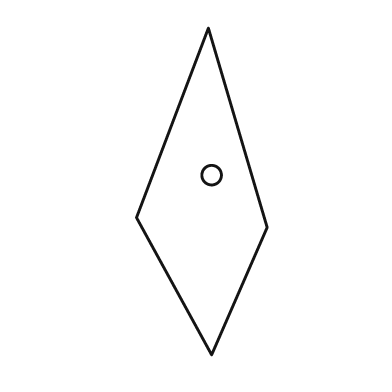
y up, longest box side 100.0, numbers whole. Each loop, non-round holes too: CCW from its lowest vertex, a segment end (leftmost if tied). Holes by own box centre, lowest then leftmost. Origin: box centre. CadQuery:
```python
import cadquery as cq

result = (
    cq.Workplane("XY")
    .moveTo(3.0, -50.0)
    .lineTo(20.0, -11.0)
    .lineTo(2.0, 50.0)
    .lineTo(-20.0, -8.0)
    .close()
    .moveTo(3.0, 5.0)
    .circle(3.0)
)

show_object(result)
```